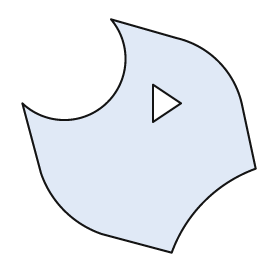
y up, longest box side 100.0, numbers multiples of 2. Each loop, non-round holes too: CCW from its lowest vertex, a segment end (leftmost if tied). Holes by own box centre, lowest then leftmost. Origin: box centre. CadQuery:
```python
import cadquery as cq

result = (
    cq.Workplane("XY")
    .moveTo(14.0, -50.0)
    .threePointArc((28.0, -28.0), (50.0, -14.0))
    .lineTo(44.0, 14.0)
    .threePointArc((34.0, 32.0), (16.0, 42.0))
    .lineTo(-12.0, 50.0)
    .threePointArc((-14.0, 14.0), (-50.0, 14.0))
    .lineTo(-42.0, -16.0)
    .threePointArc((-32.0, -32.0), (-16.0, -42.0))
    .close()
    .moveTo(6.0, 6.0)
    .lineTo(18.0, 14.0)
    .lineTo(6.0, 22.0)
    .close()
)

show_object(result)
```